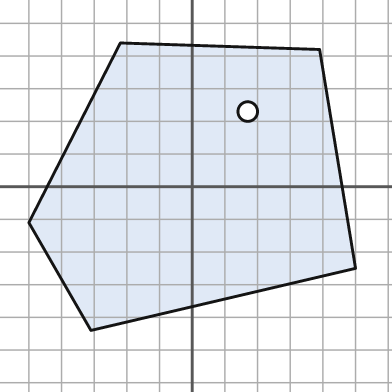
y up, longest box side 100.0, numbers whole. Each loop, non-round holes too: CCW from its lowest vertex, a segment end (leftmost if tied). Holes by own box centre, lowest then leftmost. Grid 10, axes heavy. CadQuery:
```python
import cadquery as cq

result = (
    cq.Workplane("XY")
    .moveTo(-31.0, -44.0)
    .lineTo(50.0, -25.0)
    .lineTo(39.0, 42.0)
    .lineTo(-22.0, 44.0)
    .lineTo(-50.0, -11.0)
    .close()
    .moveTo(17.0, 23.0)
    .circle(3.0)
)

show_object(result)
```